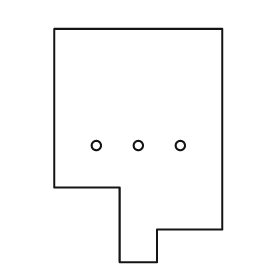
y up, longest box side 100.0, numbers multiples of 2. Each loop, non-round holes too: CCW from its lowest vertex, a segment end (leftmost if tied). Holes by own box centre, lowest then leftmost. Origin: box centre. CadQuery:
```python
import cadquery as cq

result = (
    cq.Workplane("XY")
    .moveTo(-8.0, -50.0)
    .lineTo(8.0, -50.0)
    .lineTo(8.0, -36.0)
    .lineTo(36.0, -36.0)
    .lineTo(36.0, 50.0)
    .lineTo(-36.0, 50.0)
    .lineTo(-36.0, -18.0)
    .lineTo(-8.0, -18.0)
    .close()
    .moveTo(-18.0, 0.0)
    .circle(2.0)
    .moveTo(0.0, 0.0)
    .circle(2.0)
    .moveTo(18.0, 0.0)
    .circle(2.0)
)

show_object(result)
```